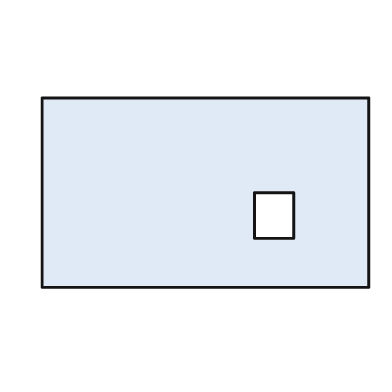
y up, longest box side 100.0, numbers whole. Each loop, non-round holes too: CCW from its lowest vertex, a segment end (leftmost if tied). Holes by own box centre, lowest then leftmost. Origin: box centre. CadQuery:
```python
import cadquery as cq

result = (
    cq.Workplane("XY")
    .moveTo(-50.0, -29.0)
    .lineTo(50.0, -29.0)
    .lineTo(50.0, 29.0)
    .lineTo(-50.0, 29.0)
    .close()
    .moveTo(15.0, -14.0)
    .lineTo(27.0, -14.0)
    .lineTo(27.0, 0.0)
    .lineTo(15.0, 0.0)
    .close()
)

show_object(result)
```